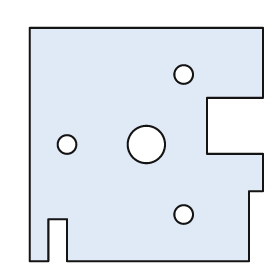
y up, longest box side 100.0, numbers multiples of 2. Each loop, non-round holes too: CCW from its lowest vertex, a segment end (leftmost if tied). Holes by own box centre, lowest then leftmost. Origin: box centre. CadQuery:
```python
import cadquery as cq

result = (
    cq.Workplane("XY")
    .moveTo(-50.0, -50.0)
    .lineTo(-42.0, -50.0)
    .lineTo(-42.0, -32.0)
    .lineTo(-34.0, -32.0)
    .lineTo(-34.0, -50.0)
    .lineTo(44.0, -50.0)
    .lineTo(44.0, -20.0)
    .lineTo(50.0, -20.0)
    .lineTo(50.0, -4.0)
    .lineTo(26.0, -4.0)
    .lineTo(26.0, 20.0)
    .lineTo(50.0, 20.0)
    .lineTo(50.0, 50.0)
    .lineTo(-50.0, 50.0)
    .close()
    .moveTo(16.0, -30.0)
    .circle(4.0)
    .moveTo(-34.0, 0.0)
    .circle(4.0)
    .moveTo(0.0, 0.0)
    .circle(8.0)
    .moveTo(16.0, 30.0)
    .circle(4.0)
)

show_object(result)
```